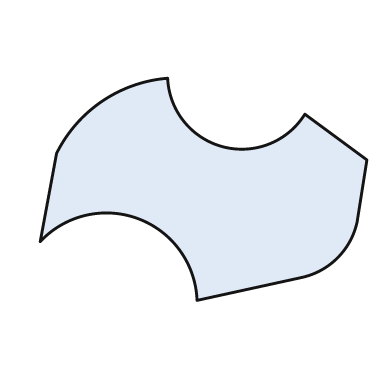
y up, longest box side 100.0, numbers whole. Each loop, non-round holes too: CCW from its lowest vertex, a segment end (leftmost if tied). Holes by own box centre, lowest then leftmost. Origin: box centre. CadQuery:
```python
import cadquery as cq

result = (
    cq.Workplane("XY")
    .moveTo(-2.0, -34.0)
    .lineTo(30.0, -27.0)
    .threePointArc((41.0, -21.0), (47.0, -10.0))
    .lineTo(50.0, 9.0)
    .lineTo(31.0, 23.0)
    .threePointArc((6.0, 13.0), (-11.0, 34.0))
    .threePointArc((-31.0, 27.0), (-45.0, 11.0))
    .lineTo(-50.0, -16.0)
    .threePointArc((-20.0, -9.0), (-2.0, -34.0))
    .close()
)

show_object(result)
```